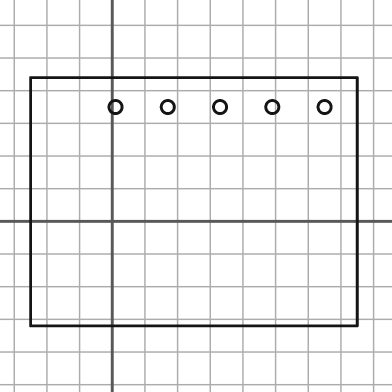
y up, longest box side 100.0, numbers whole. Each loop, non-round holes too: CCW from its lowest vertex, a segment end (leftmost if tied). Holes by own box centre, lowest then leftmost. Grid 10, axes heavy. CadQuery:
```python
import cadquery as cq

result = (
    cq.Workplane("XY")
    .moveTo(-25.0, -32.0)
    .lineTo(75.0, -32.0)
    .lineTo(75.0, 44.0)
    .lineTo(-25.0, 44.0)
    .close()
    .moveTo(1.0, 35.0)
    .circle(2.0)
    .moveTo(17.0, 35.0)
    .circle(2.0)
    .moveTo(33.0, 35.0)
    .circle(2.0)
    .moveTo(49.0, 35.0)
    .circle(2.0)
    .moveTo(65.0, 35.0)
    .circle(2.0)
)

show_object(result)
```